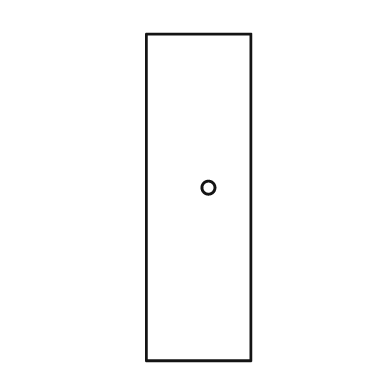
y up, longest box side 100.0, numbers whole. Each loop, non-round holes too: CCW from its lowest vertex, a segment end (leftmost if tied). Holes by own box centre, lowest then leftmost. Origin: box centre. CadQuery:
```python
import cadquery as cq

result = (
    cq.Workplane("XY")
    .moveTo(-16.0, -50.0)
    .lineTo(16.0, -50.0)
    .lineTo(16.0, 50.0)
    .lineTo(-16.0, 50.0)
    .close()
    .moveTo(3.0, 3.0)
    .circle(2.0)
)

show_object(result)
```